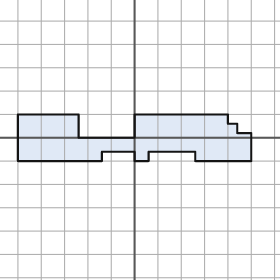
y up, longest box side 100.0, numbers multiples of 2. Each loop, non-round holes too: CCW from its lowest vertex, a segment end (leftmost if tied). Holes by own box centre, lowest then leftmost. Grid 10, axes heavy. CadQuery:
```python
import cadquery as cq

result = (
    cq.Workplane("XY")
    .moveTo(-50.0, -10.0)
    .lineTo(-14.0, -10.0)
    .lineTo(-14.0, -6.0)
    .lineTo(0.0, -6.0)
    .lineTo(0.0, -10.0)
    .lineTo(6.0, -10.0)
    .lineTo(6.0, -6.0)
    .lineTo(26.0, -6.0)
    .lineTo(26.0, -10.0)
    .lineTo(50.0, -10.0)
    .lineTo(50.0, 2.0)
    .lineTo(44.0, 2.0)
    .lineTo(44.0, 6.0)
    .lineTo(40.0, 6.0)
    .lineTo(40.0, 10.0)
    .lineTo(0.0, 10.0)
    .lineTo(0.0, 0.0)
    .lineTo(-24.0, 0.0)
    .lineTo(-24.0, 10.0)
    .lineTo(-50.0, 10.0)
    .close()
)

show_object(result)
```